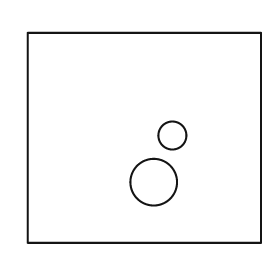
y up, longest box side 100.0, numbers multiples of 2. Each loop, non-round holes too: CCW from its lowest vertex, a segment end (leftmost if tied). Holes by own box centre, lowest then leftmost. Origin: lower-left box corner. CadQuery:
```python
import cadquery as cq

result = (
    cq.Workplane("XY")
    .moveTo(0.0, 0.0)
    .lineTo(100.0, 0.0)
    .lineTo(100.0, 90.0)
    .lineTo(0.0, 90.0)
    .close()
    .moveTo(54.0, 26.0)
    .circle(10.0)
    .moveTo(62.0, 46.0)
    .circle(6.0)
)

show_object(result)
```